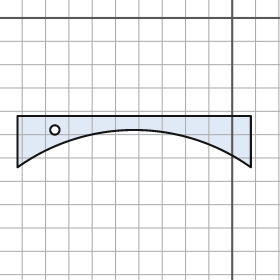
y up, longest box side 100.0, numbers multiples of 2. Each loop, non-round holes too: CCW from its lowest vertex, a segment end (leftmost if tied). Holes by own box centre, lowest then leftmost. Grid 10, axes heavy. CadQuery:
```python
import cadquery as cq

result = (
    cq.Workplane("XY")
    .moveTo(-92.0, -64.0)
    .threePointArc((-42.0, -48.0), (8.0, -64.0))
    .lineTo(8.0, -42.0)
    .lineTo(-92.0, -42.0)
    .close()
    .moveTo(-76.0, -48.0)
    .circle(2.0)
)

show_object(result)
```